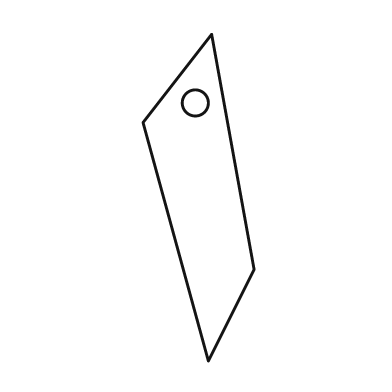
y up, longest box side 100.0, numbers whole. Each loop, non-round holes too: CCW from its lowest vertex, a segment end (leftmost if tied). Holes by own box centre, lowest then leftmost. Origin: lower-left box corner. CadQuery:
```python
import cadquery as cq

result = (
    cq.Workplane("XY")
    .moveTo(20.0, 0.0)
    .lineTo(34.0, 28.0)
    .lineTo(21.0, 100.0)
    .lineTo(0.0, 73.0)
    .close()
    .moveTo(16.0, 79.0)
    .circle(4.0)
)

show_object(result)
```